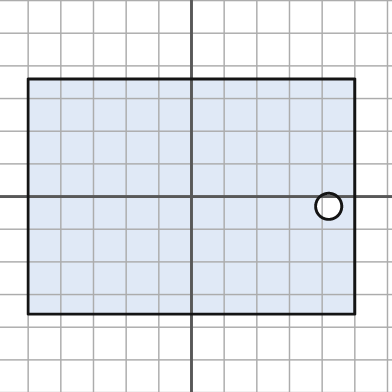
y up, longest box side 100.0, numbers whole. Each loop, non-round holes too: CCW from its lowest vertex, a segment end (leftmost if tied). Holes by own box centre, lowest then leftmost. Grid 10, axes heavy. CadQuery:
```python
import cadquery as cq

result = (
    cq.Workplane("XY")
    .moveTo(-50.0, -36.0)
    .lineTo(50.0, -36.0)
    .lineTo(50.0, 36.0)
    .lineTo(-50.0, 36.0)
    .close()
    .moveTo(42.0, -3.0)
    .circle(4.0)
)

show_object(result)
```